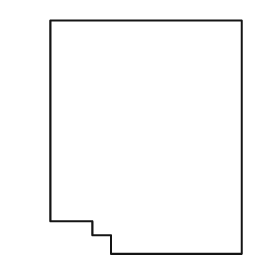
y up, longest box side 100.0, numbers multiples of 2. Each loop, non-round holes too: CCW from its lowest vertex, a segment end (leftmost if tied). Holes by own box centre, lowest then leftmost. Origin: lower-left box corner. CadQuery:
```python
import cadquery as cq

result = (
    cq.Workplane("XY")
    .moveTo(26.0, 0.0)
    .lineTo(82.0, 0.0)
    .lineTo(82.0, 100.0)
    .lineTo(0.0, 100.0)
    .lineTo(0.0, 14.0)
    .lineTo(18.0, 14.0)
    .lineTo(18.0, 8.0)
    .lineTo(26.0, 8.0)
    .close()
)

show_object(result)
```